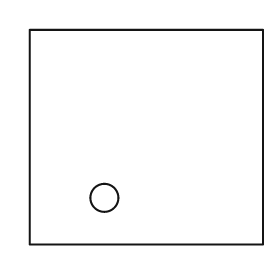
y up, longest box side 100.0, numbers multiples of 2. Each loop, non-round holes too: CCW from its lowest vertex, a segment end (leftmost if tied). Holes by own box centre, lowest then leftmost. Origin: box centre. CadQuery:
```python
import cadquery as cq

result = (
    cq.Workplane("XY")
    .moveTo(-50.0, -46.0)
    .lineTo(50.0, -46.0)
    .lineTo(50.0, 46.0)
    .lineTo(-50.0, 46.0)
    .close()
    .moveTo(-18.0, -26.0)
    .circle(6.0)
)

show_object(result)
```